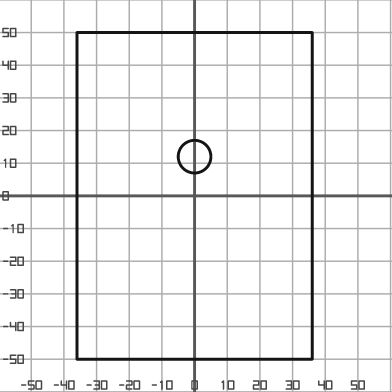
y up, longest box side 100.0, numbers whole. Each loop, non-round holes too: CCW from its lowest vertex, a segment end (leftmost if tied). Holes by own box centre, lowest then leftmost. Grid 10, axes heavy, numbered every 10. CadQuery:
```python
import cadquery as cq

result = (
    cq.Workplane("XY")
    .moveTo(-36.0, -50.0)
    .lineTo(36.0, -50.0)
    .lineTo(36.0, 50.0)
    .lineTo(-36.0, 50.0)
    .close()
    .moveTo(0.0, 12.0)
    .circle(5.0)
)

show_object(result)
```